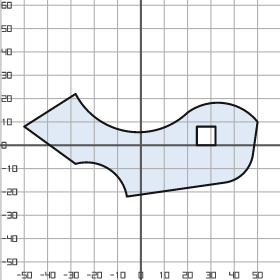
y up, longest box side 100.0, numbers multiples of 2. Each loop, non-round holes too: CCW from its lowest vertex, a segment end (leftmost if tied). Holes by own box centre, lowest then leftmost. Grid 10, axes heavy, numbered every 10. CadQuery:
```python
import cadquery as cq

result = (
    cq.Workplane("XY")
    .moveTo(-6.0, -22.0)
    .lineTo(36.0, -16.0)
    .threePointArc((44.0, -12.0), (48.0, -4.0))
    .lineTo(50.0, 10.0)
    .threePointArc((36.0, 18.0), (20.0, 14.0))
    .threePointArc((-6.0, 6.0), (-28.0, 22.0))
    .lineTo(-50.0, 8.0)
    .lineTo(-28.0, -8.0)
    .threePointArc((-14.0, -10.0), (-6.0, -22.0))
    .close()
    .moveTo(24.0, 0.0)
    .lineTo(32.0, 0.0)
    .lineTo(32.0, 8.0)
    .lineTo(24.0, 8.0)
    .close()
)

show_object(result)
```